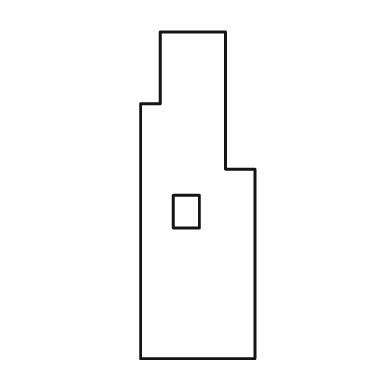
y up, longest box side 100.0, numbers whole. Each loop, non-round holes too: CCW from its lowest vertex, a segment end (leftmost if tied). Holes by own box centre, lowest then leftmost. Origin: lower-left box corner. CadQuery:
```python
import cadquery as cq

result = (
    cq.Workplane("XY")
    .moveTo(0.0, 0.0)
    .lineTo(35.0, 0.0)
    .lineTo(35.0, 58.0)
    .lineTo(26.0, 58.0)
    .lineTo(26.0, 100.0)
    .lineTo(6.0, 100.0)
    .lineTo(6.0, 78.0)
    .lineTo(0.0, 78.0)
    .close()
    .moveTo(10.0, 40.0)
    .lineTo(18.0, 40.0)
    .lineTo(18.0, 50.0)
    .lineTo(10.0, 50.0)
    .close()
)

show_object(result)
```